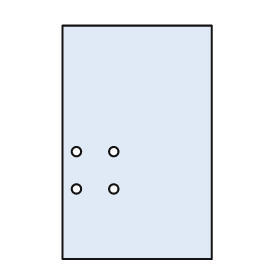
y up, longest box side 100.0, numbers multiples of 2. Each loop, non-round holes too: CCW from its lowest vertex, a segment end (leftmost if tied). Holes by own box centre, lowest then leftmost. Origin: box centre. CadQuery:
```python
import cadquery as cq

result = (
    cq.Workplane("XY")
    .moveTo(-32.0, -50.0)
    .lineTo(32.0, -50.0)
    .lineTo(32.0, 50.0)
    .lineTo(-32.0, 50.0)
    .close()
    .moveTo(-26.0, -20.0)
    .circle(2.0)
    .moveTo(-10.0, -20.0)
    .circle(2.0)
    .moveTo(-26.0, -4.0)
    .circle(2.0)
    .moveTo(-10.0, -4.0)
    .circle(2.0)
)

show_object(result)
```